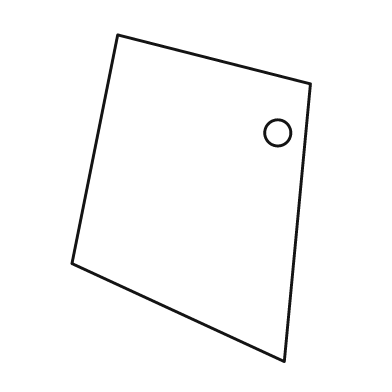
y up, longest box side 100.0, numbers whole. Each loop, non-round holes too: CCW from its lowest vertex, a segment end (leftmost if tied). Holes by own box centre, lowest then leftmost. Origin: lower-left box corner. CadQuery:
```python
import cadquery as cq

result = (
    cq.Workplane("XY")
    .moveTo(65.0, 0.0)
    .lineTo(73.0, 85.0)
    .lineTo(14.0, 100.0)
    .lineTo(0.0, 30.0)
    .close()
    .moveTo(63.0, 70.0)
    .circle(4.0)
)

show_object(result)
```